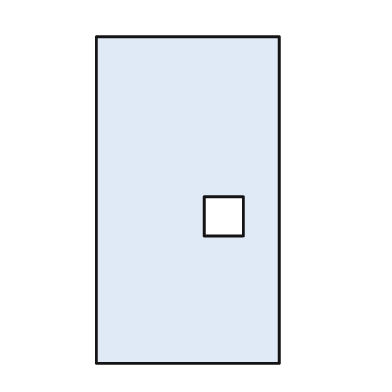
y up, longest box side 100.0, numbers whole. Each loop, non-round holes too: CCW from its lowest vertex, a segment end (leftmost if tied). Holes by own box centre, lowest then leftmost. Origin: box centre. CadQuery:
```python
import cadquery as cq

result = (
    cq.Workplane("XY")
    .moveTo(-28.0, -50.0)
    .lineTo(28.0, -50.0)
    .lineTo(28.0, 50.0)
    .lineTo(-28.0, 50.0)
    .close()
    .moveTo(5.0, -11.0)
    .lineTo(17.0, -11.0)
    .lineTo(17.0, 1.0)
    .lineTo(5.0, 1.0)
    .close()
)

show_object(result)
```